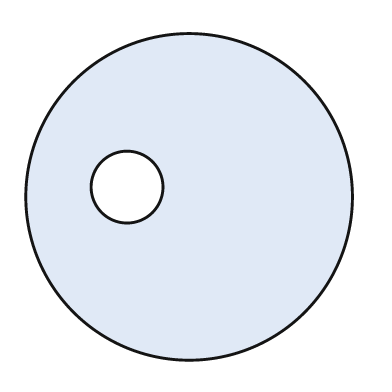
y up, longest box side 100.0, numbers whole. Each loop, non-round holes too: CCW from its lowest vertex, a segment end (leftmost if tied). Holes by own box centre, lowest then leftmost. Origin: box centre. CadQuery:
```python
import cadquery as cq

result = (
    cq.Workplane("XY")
    .moveTo(0.0, 0.0)
    .circle(50.0)
    .moveTo(-19.0, 3.0)
    .circle(11.0)
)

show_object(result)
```